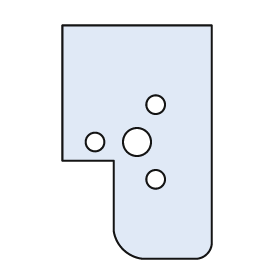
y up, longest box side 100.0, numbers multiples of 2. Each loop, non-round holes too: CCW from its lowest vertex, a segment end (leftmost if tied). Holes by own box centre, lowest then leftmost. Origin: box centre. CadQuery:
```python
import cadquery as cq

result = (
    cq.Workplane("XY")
    .moveTo(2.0, -50.0)
    .lineTo(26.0, -50.0)
    .threePointArc((30.0, -48.0), (32.0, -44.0))
    .lineTo(32.0, 50.0)
    .lineTo(-32.0, 50.0)
    .lineTo(-32.0, -8.0)
    .lineTo(-10.0, -8.0)
    .lineTo(-10.0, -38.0)
    .threePointArc((-6.0, -46.0), (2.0, -50.0))
    .close()
    .moveTo(8.0, -16.0)
    .circle(4.0)
    .moveTo(-18.0, 0.0)
    .circle(4.0)
    .moveTo(0.0, 0.0)
    .circle(6.0)
    .moveTo(8.0, 16.0)
    .circle(4.0)
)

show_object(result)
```